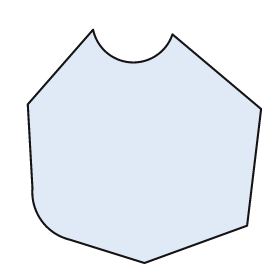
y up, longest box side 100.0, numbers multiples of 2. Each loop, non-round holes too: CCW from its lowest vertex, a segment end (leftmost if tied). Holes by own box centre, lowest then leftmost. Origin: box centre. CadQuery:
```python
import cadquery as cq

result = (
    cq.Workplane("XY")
    .moveTo(0.0, -50.0)
    .lineTo(44.0, -34.0)
    .lineTo(50.0, 16.0)
    .lineTo(12.0, 48.0)
    .threePointArc((-6.0, 36.0), (-22.0, 50.0))
    .lineTo(-50.0, 18.0)
    .lineTo(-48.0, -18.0)
    .threePointArc((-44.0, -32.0), (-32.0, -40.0))
    .close()
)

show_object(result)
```